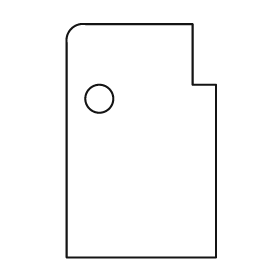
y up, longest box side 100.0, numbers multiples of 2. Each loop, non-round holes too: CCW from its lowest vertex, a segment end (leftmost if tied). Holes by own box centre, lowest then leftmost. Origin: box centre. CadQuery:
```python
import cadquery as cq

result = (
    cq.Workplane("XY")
    .moveTo(-32.0, -50.0)
    .lineTo(32.0, -50.0)
    .lineTo(32.0, 24.0)
    .lineTo(22.0, 24.0)
    .lineTo(22.0, 50.0)
    .lineTo(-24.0, 50.0)
    .threePointArc((-30.0, 48.0), (-32.0, 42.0))
    .close()
    .moveTo(-18.0, 18.0)
    .circle(6.0)
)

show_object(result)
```